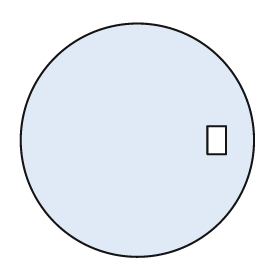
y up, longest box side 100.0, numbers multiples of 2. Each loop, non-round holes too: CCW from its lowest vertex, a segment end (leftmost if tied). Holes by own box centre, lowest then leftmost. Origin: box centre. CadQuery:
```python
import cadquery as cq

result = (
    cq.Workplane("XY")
    .moveTo(0.0, 0.0)
    .circle(50.0)
    .moveTo(30.0, -6.0)
    .lineTo(38.0, -6.0)
    .lineTo(38.0, 6.0)
    .lineTo(30.0, 6.0)
    .close()
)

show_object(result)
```